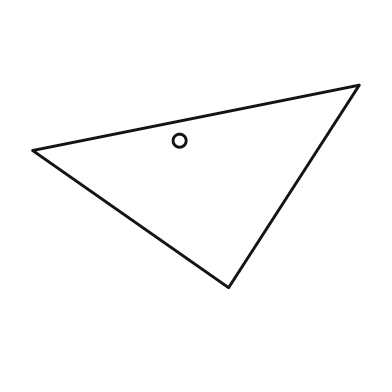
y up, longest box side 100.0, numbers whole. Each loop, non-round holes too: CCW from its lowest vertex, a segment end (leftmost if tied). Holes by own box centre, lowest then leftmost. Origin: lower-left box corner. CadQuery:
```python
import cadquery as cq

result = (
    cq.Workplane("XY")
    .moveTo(60.0, 0.0)
    .lineTo(100.0, 62.0)
    .lineTo(0.0, 42.0)
    .close()
    .moveTo(45.0, 45.0)
    .circle(2.0)
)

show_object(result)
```